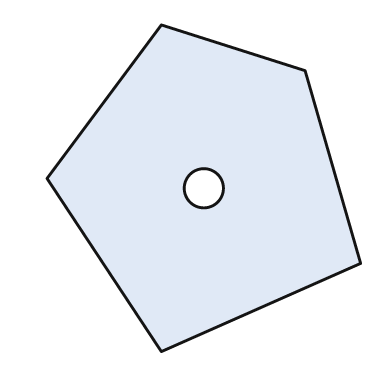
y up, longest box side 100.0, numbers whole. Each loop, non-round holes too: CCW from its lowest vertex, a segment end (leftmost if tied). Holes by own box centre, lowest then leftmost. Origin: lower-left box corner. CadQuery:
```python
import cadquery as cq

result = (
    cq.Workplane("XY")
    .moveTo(35.0, 0.0)
    .lineTo(96.0, 27.0)
    .lineTo(79.0, 86.0)
    .lineTo(35.0, 100.0)
    .lineTo(0.0, 53.0)
    .close()
    .moveTo(48.0, 50.0)
    .circle(6.0)
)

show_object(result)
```